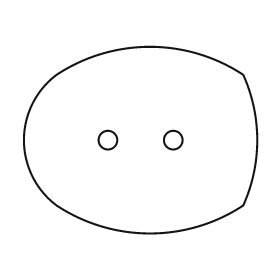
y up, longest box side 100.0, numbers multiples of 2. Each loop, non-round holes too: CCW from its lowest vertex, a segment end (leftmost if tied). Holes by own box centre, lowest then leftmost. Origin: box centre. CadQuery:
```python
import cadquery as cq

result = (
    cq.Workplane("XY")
    .moveTo(-36.0, -28.0)
    .threePointArc((4.0, -40.0), (44.0, -28.0))
    .threePointArc((50.0, 0.0), (44.0, 28.0))
    .threePointArc((4.0, 40.0), (-36.0, 28.0))
    .threePointArc((-50.0, 0.0), (-36.0, -28.0))
    .close()
    .moveTo(-14.0, 0.0)
    .circle(4.0)
    .moveTo(14.0, 0.0)
    .circle(4.0)
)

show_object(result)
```